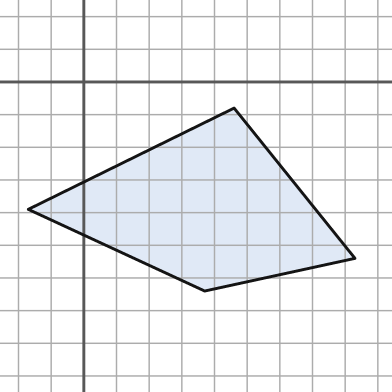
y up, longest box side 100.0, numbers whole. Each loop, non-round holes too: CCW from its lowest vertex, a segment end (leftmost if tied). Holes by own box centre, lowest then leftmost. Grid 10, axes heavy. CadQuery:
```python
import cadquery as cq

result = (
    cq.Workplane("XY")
    .moveTo(37.0, -64.0)
    .lineTo(83.0, -54.0)
    .lineTo(46.0, -8.0)
    .lineTo(-17.0, -39.0)
    .close()
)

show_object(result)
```